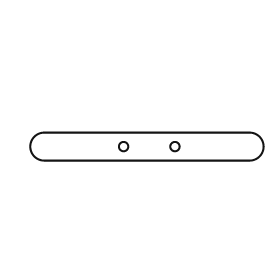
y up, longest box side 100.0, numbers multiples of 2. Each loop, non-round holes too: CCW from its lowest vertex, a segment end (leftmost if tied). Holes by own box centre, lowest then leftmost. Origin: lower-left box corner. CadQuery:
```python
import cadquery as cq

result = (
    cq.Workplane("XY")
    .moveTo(6.0, 0.0)
    .lineTo(94.0, 0.0)
    .threePointArc((100.0, 6.0), (94.0, 12.0))
    .lineTo(6.0, 12.0)
    .threePointArc((0.0, 6.0), (6.0, 0.0))
    .close()
    .moveTo(40.0, 6.0)
    .circle(2.0)
    .moveTo(62.0, 6.0)
    .circle(2.0)
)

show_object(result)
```